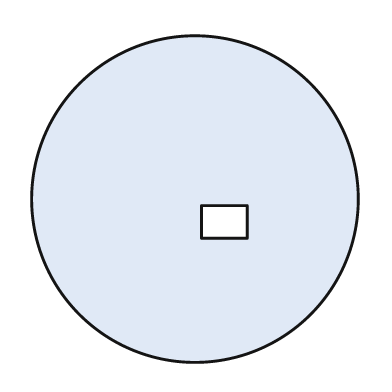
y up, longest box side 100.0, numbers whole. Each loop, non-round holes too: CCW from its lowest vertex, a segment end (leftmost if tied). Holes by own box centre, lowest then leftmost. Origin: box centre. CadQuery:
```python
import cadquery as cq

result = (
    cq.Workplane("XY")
    .moveTo(0.0, 0.0)
    .circle(50.0)
    .moveTo(2.0, -12.0)
    .lineTo(16.0, -12.0)
    .lineTo(16.0, -2.0)
    .lineTo(2.0, -2.0)
    .close()
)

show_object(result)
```